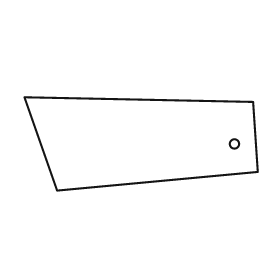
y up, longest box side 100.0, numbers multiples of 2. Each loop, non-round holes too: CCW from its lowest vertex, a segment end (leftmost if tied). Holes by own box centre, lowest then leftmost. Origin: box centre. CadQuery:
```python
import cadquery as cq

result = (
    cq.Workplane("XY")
    .moveTo(-36.0, -20.0)
    .lineTo(50.0, -12.0)
    .lineTo(48.0, 18.0)
    .lineTo(-50.0, 20.0)
    .close()
    .moveTo(40.0, 0.0)
    .circle(2.0)
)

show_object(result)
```